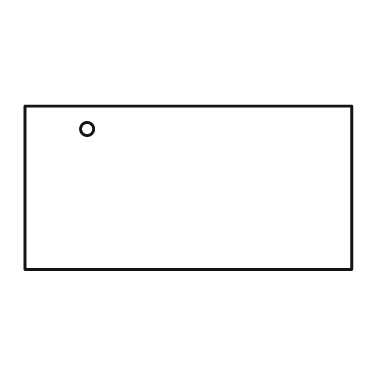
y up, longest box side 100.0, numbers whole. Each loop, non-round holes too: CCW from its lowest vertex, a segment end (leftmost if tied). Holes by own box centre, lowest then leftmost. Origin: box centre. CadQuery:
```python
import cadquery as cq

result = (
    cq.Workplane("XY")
    .moveTo(-50.0, -25.0)
    .lineTo(50.0, -25.0)
    .lineTo(50.0, 25.0)
    .lineTo(-50.0, 25.0)
    .close()
    .moveTo(-31.0, 18.0)
    .circle(2.0)
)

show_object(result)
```